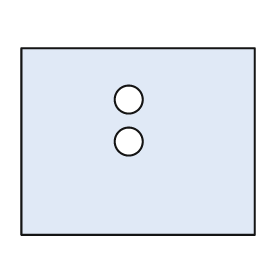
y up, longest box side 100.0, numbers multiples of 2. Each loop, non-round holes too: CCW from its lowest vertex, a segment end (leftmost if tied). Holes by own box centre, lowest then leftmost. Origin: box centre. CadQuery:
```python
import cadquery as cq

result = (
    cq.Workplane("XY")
    .moveTo(-50.0, -40.0)
    .lineTo(50.0, -40.0)
    .lineTo(50.0, 40.0)
    .lineTo(-50.0, 40.0)
    .close()
    .moveTo(-4.0, 0.0)
    .circle(6.0)
    .moveTo(-4.0, 18.0)
    .circle(6.0)
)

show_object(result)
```